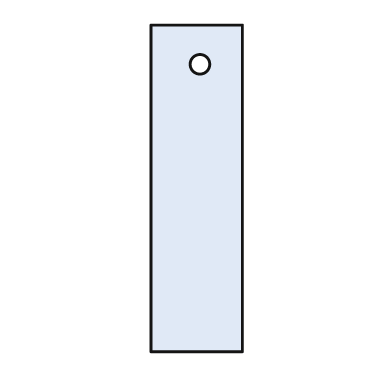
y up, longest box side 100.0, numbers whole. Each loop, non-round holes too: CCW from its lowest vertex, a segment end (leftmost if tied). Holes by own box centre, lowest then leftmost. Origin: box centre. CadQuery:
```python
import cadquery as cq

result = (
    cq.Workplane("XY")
    .moveTo(-14.0, -50.0)
    .lineTo(14.0, -50.0)
    .lineTo(14.0, 50.0)
    .lineTo(-14.0, 50.0)
    .close()
    .moveTo(1.0, 38.0)
    .circle(3.0)
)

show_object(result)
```